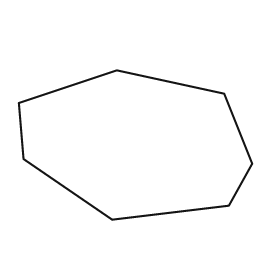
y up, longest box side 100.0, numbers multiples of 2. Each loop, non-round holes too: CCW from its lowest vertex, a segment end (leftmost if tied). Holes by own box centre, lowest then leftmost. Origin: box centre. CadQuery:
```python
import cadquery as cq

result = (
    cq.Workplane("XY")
    .moveTo(-10.0, -32.0)
    .lineTo(40.0, -26.0)
    .lineTo(50.0, -8.0)
    .lineTo(38.0, 22.0)
    .lineTo(-8.0, 32.0)
    .lineTo(-50.0, 18.0)
    .lineTo(-48.0, -6.0)
    .close()
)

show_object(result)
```